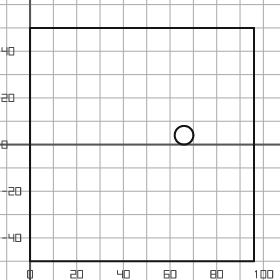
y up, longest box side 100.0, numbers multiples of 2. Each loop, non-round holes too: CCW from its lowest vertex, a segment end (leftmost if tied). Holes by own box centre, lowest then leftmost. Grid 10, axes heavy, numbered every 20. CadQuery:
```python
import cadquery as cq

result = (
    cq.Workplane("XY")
    .moveTo(0.0, -50.0)
    .lineTo(96.0, -50.0)
    .lineTo(96.0, 50.0)
    .lineTo(0.0, 50.0)
    .close()
    .moveTo(66.0, 4.0)
    .circle(4.0)
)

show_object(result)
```